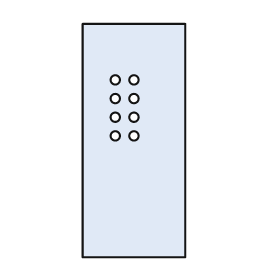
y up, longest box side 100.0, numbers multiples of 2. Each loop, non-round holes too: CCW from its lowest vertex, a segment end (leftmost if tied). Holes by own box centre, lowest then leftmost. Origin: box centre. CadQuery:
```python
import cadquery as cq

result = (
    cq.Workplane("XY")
    .moveTo(-22.0, -50.0)
    .lineTo(22.0, -50.0)
    .lineTo(22.0, 50.0)
    .lineTo(-22.0, 50.0)
    .close()
    .moveTo(-8.0, 2.0)
    .circle(2.0)
    .moveTo(0.0, 2.0)
    .circle(2.0)
    .moveTo(-8.0, 10.0)
    .circle(2.0)
    .moveTo(0.0, 10.0)
    .circle(2.0)
    .moveTo(-8.0, 18.0)
    .circle(2.0)
    .moveTo(0.0, 18.0)
    .circle(2.0)
    .moveTo(-8.0, 26.0)
    .circle(2.0)
    .moveTo(0.0, 26.0)
    .circle(2.0)
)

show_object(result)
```